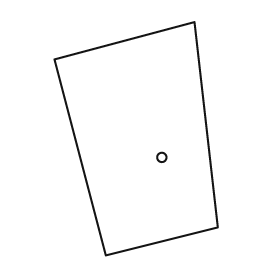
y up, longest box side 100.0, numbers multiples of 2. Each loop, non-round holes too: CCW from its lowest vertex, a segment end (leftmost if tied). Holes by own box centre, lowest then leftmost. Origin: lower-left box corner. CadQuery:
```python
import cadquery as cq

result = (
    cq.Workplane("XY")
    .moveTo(22.0, 0.0)
    .lineTo(70.0, 12.0)
    .lineTo(60.0, 100.0)
    .lineTo(0.0, 84.0)
    .close()
    .moveTo(46.0, 42.0)
    .circle(2.0)
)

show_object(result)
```